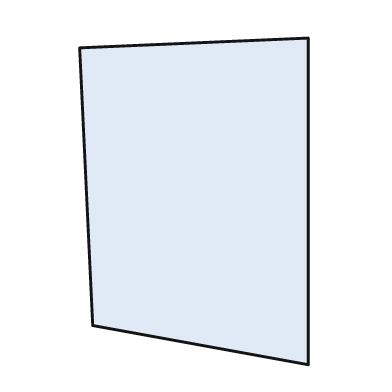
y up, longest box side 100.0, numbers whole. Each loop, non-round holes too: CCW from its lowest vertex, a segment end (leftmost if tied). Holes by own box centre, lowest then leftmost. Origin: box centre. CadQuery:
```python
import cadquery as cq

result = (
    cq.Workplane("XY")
    .moveTo(35.0, -50.0)
    .lineTo(35.0, 50.0)
    .lineTo(-35.0, 47.0)
    .lineTo(-31.0, -38.0)
    .close()
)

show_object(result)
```